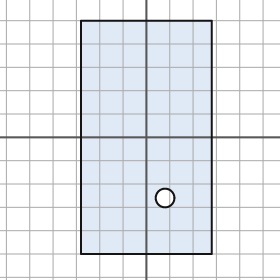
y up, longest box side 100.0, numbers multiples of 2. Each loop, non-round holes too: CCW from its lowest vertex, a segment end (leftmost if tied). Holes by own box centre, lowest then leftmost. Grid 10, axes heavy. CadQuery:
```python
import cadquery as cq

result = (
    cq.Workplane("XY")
    .moveTo(-28.0, -50.0)
    .lineTo(28.0, -50.0)
    .lineTo(28.0, 50.0)
    .lineTo(-28.0, 50.0)
    .close()
    .moveTo(8.0, -26.0)
    .circle(4.0)
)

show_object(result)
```